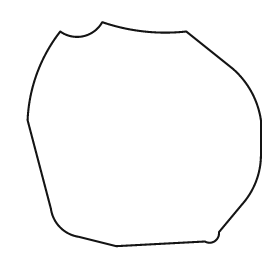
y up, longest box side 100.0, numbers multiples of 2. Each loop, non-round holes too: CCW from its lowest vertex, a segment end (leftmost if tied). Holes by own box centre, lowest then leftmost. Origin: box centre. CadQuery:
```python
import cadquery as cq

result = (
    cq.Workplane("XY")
    .moveTo(-12.0, -48.0)
    .lineTo(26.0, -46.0)
    .threePointArc((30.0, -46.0), (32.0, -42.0))
    .lineTo(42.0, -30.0)
    .threePointArc((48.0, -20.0), (50.0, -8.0))
    .lineTo(50.0, 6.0)
    .threePointArc((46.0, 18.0), (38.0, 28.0))
    .lineTo(18.0, 44.0)
    .threePointArc((0.0, 44.0), (-18.0, 48.0))
    .threePointArc((-26.0, 42.0), (-36.0, 44.0))
    .threePointArc((-46.0, 26.0), (-50.0, 6.0))
    .lineTo(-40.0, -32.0)
    .threePointArc((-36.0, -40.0), (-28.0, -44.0))
    .close()
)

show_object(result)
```